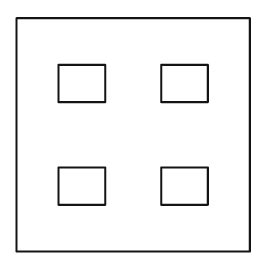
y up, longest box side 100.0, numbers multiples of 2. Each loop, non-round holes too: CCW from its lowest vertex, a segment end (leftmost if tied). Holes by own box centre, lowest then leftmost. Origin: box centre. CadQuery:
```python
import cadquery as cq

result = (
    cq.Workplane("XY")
    .moveTo(-50.0, -50.0)
    .lineTo(50.0, -50.0)
    .lineTo(50.0, 50.0)
    .lineTo(-50.0, 50.0)
    .close()
    .moveTo(-32.0, -30.0)
    .lineTo(-12.0, -30.0)
    .lineTo(-12.0, -14.0)
    .lineTo(-32.0, -14.0)
    .close()
    .moveTo(12.0, -30.0)
    .lineTo(32.0, -30.0)
    .lineTo(32.0, -14.0)
    .lineTo(12.0, -14.0)
    .close()
    .moveTo(-32.0, 14.0)
    .lineTo(-12.0, 14.0)
    .lineTo(-12.0, 30.0)
    .lineTo(-32.0, 30.0)
    .close()
    .moveTo(12.0, 14.0)
    .lineTo(32.0, 14.0)
    .lineTo(32.0, 30.0)
    .lineTo(12.0, 30.0)
    .close()
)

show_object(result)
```